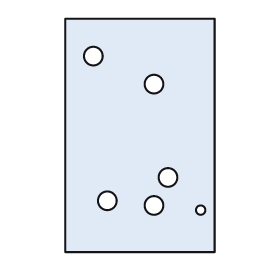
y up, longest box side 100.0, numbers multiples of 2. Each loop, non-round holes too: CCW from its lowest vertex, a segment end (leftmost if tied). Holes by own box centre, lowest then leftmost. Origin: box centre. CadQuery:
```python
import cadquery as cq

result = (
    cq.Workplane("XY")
    .moveTo(-32.0, -50.0)
    .lineTo(32.0, -50.0)
    .lineTo(32.0, 50.0)
    .lineTo(-32.0, 50.0)
    .close()
    .moveTo(26.0, -32.0)
    .circle(2.0)
    .moveTo(6.0, -30.0)
    .circle(4.0)
    .moveTo(-14.0, -28.0)
    .circle(4.0)
    .moveTo(12.0, -18.0)
    .circle(4.0)
    .moveTo(6.0, 22.0)
    .circle(4.0)
    .moveTo(-20.0, 34.0)
    .circle(4.0)
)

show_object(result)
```